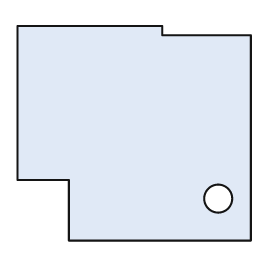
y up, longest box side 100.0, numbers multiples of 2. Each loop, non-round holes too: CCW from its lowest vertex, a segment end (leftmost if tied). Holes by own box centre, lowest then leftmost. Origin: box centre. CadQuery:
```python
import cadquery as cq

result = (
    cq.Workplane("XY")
    .moveTo(-28.0, -46.0)
    .lineTo(50.0, -46.0)
    .lineTo(50.0, 42.0)
    .lineTo(12.0, 42.0)
    .lineTo(12.0, 46.0)
    .lineTo(-50.0, 46.0)
    .lineTo(-50.0, -20.0)
    .lineTo(-28.0, -20.0)
    .close()
    .moveTo(36.0, -28.0)
    .circle(6.0)
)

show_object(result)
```